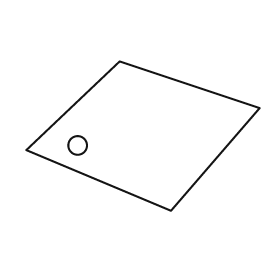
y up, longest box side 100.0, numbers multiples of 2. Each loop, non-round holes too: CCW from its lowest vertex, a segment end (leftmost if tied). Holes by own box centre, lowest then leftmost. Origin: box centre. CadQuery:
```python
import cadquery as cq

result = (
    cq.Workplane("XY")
    .moveTo(12.0, -32.0)
    .lineTo(50.0, 12.0)
    .lineTo(-10.0, 32.0)
    .lineTo(-50.0, -6.0)
    .close()
    .moveTo(-28.0, -4.0)
    .circle(4.0)
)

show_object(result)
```